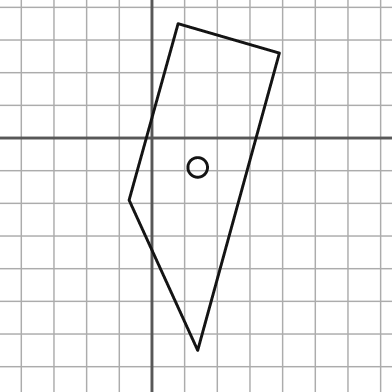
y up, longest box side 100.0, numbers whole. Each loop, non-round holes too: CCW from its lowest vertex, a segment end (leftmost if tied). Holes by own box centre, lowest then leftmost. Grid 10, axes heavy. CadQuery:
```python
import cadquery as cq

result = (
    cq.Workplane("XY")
    .moveTo(14.0, -65.0)
    .lineTo(39.0, 26.0)
    .lineTo(8.0, 35.0)
    .lineTo(-7.0, -19.0)
    .close()
    .moveTo(14.0, -9.0)
    .circle(3.0)
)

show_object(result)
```